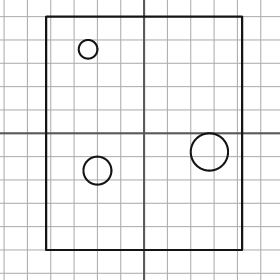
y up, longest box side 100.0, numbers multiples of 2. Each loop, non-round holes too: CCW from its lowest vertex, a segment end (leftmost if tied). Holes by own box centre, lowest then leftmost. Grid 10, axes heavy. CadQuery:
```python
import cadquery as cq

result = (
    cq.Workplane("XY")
    .moveTo(-42.0, -50.0)
    .lineTo(42.0, -50.0)
    .lineTo(42.0, 50.0)
    .lineTo(-42.0, 50.0)
    .close()
    .moveTo(-20.0, -16.0)
    .circle(6.0)
    .moveTo(28.0, -8.0)
    .circle(8.0)
    .moveTo(-24.0, 36.0)
    .circle(4.0)
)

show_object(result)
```